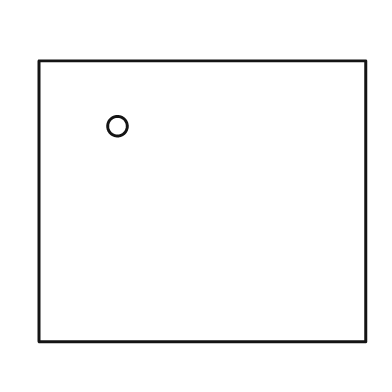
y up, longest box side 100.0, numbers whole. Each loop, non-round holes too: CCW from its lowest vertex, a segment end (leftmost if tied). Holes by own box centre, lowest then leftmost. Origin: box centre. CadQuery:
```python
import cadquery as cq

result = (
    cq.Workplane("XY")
    .moveTo(-50.0, -43.0)
    .lineTo(50.0, -43.0)
    .lineTo(50.0, 43.0)
    .lineTo(-50.0, 43.0)
    .close()
    .moveTo(-26.0, 23.0)
    .circle(3.0)
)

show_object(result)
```